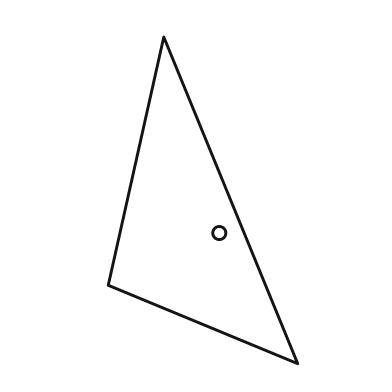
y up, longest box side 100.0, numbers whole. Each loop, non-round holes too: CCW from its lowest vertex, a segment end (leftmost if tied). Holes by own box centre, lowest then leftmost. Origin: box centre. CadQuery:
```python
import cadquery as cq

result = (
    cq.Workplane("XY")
    .moveTo(29.0, -50.0)
    .lineTo(-12.0, 50.0)
    .lineTo(-29.0, -26.0)
    .close()
    .moveTo(5.0, -10.0)
    .circle(2.0)
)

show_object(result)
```